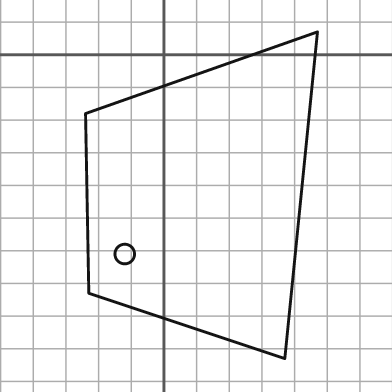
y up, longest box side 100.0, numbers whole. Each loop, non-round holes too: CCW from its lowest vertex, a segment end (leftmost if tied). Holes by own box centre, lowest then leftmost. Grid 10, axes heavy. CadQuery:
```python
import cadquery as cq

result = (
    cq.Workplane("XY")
    .moveTo(37.0, -93.0)
    .lineTo(47.0, 7.0)
    .lineTo(-24.0, -18.0)
    .lineTo(-23.0, -73.0)
    .close()
    .moveTo(-12.0, -61.0)
    .circle(3.0)
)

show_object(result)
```